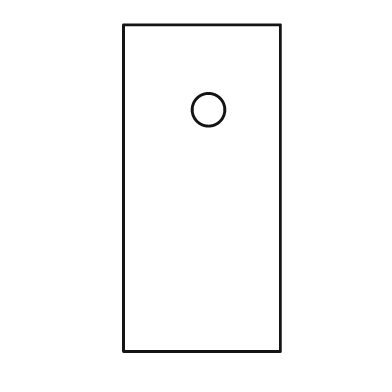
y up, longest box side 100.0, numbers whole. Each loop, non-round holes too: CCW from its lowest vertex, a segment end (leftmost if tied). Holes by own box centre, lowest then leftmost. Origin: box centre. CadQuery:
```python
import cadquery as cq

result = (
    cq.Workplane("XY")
    .moveTo(-24.0, -50.0)
    .lineTo(24.0, -50.0)
    .lineTo(24.0, 50.0)
    .lineTo(-24.0, 50.0)
    .close()
    .moveTo(2.0, 24.0)
    .circle(5.0)
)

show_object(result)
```